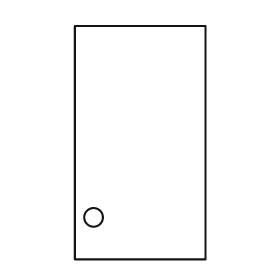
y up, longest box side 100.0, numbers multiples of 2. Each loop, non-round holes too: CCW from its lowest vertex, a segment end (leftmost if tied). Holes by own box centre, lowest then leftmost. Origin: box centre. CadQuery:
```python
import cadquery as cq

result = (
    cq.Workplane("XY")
    .moveTo(-28.0, -50.0)
    .lineTo(28.0, -50.0)
    .lineTo(28.0, 50.0)
    .lineTo(-28.0, 50.0)
    .close()
    .moveTo(-20.0, -32.0)
    .circle(4.0)
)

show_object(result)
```